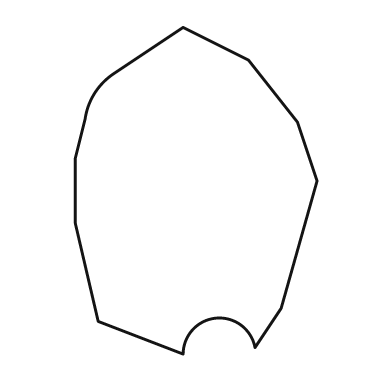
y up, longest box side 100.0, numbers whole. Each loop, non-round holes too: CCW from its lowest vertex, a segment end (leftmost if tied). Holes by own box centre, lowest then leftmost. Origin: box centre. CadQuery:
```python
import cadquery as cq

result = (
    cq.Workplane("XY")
    .moveTo(-4.0, -50.0)
    .threePointArc((6.0, -39.0), (18.0, -48.0))
    .lineTo(26.0, -36.0)
    .lineTo(37.0, 3.0)
    .lineTo(31.0, 21.0)
    .lineTo(16.0, 40.0)
    .lineTo(-4.0, 50.0)
    .lineTo(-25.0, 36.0)
    .threePointArc((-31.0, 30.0), (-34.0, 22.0))
    .lineTo(-37.0, 10.0)
    .lineTo(-37.0, -10.0)
    .lineTo(-30.0, -40.0)
    .close()
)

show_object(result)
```